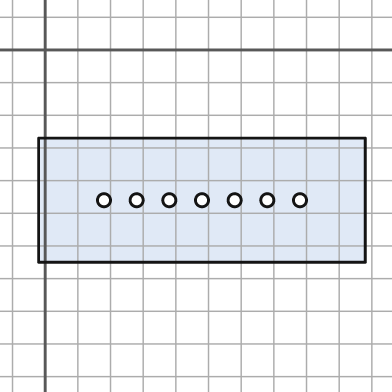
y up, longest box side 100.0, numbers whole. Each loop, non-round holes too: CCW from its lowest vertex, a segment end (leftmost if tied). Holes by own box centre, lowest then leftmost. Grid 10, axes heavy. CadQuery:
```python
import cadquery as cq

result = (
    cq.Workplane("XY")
    .moveTo(-2.0, -65.0)
    .lineTo(98.0, -65.0)
    .lineTo(98.0, -27.0)
    .lineTo(-2.0, -27.0)
    .close()
    .moveTo(18.0, -46.0)
    .circle(2.0)
    .moveTo(28.0, -46.0)
    .circle(2.0)
    .moveTo(38.0, -46.0)
    .circle(2.0)
    .moveTo(48.0, -46.0)
    .circle(2.0)
    .moveTo(58.0, -46.0)
    .circle(2.0)
    .moveTo(68.0, -46.0)
    .circle(2.0)
    .moveTo(78.0, -46.0)
    .circle(2.0)
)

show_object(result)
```